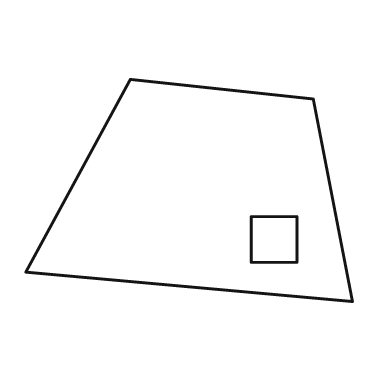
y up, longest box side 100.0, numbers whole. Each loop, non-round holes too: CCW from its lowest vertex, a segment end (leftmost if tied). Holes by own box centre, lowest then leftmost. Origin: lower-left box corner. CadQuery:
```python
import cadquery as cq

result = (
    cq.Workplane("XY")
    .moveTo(100.0, 0.0)
    .lineTo(88.0, 62.0)
    .lineTo(32.0, 68.0)
    .lineTo(0.0, 9.0)
    .close()
    .moveTo(69.0, 12.0)
    .lineTo(83.0, 12.0)
    .lineTo(83.0, 26.0)
    .lineTo(69.0, 26.0)
    .close()
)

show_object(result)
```